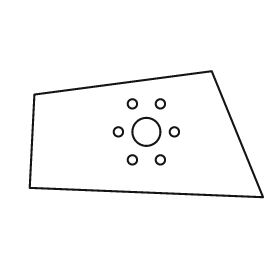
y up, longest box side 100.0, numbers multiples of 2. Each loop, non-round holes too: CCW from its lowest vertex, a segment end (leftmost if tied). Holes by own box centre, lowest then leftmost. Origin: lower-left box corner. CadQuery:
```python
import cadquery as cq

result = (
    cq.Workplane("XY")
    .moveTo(100.0, 0.0)
    .lineTo(78.0, 54.0)
    .lineTo(2.0, 44.0)
    .lineTo(0.0, 4.0)
    .close()
    .moveTo(44.0, 16.0)
    .circle(2.0)
    .moveTo(56.0, 16.0)
    .circle(2.0)
    .moveTo(38.0, 28.0)
    .circle(2.0)
    .moveTo(50.0, 28.0)
    .circle(6.0)
    .moveTo(62.0, 28.0)
    .circle(2.0)
    .moveTo(44.0, 40.0)
    .circle(2.0)
    .moveTo(56.0, 40.0)
    .circle(2.0)
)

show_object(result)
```